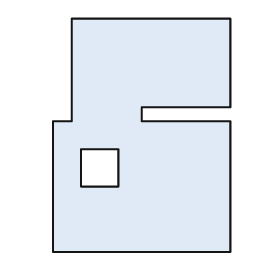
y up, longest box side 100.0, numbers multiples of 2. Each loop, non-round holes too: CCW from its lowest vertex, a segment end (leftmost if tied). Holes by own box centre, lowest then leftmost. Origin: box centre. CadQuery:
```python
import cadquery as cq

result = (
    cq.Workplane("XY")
    .moveTo(-38.0, -50.0)
    .lineTo(38.0, -50.0)
    .lineTo(38.0, 6.0)
    .lineTo(0.0, 6.0)
    .lineTo(0.0, 12.0)
    .lineTo(38.0, 12.0)
    .lineTo(38.0, 50.0)
    .lineTo(-30.0, 50.0)
    .lineTo(-30.0, 6.0)
    .lineTo(-38.0, 6.0)
    .close()
    .moveTo(-26.0, -22.0)
    .lineTo(-10.0, -22.0)
    .lineTo(-10.0, -6.0)
    .lineTo(-26.0, -6.0)
    .close()
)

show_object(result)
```